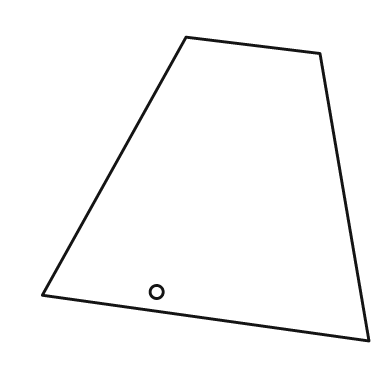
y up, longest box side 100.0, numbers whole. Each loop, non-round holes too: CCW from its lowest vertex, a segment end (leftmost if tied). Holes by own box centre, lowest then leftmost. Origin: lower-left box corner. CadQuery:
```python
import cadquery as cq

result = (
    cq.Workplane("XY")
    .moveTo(100.0, 0.0)
    .lineTo(85.0, 88.0)
    .lineTo(44.0, 93.0)
    .lineTo(0.0, 14.0)
    .close()
    .moveTo(35.0, 15.0)
    .circle(2.0)
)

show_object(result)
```